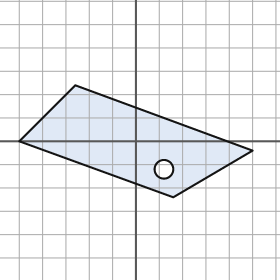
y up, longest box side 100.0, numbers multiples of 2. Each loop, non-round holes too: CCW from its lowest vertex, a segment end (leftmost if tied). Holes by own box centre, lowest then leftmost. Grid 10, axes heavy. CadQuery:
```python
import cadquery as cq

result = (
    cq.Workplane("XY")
    .moveTo(16.0, -24.0)
    .lineTo(50.0, -4.0)
    .lineTo(-26.0, 24.0)
    .lineTo(-50.0, 0.0)
    .close()
    .moveTo(12.0, -12.0)
    .circle(4.0)
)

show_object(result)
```